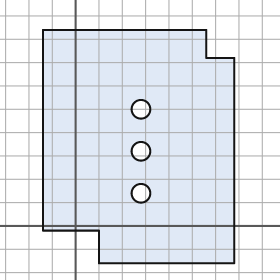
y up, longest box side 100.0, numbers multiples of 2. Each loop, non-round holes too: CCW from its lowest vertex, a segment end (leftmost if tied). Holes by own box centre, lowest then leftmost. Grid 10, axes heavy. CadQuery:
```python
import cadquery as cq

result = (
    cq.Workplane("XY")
    .moveTo(10.0, -16.0)
    .lineTo(68.0, -16.0)
    .lineTo(68.0, 72.0)
    .lineTo(56.0, 72.0)
    .lineTo(56.0, 84.0)
    .lineTo(-14.0, 84.0)
    .lineTo(-14.0, -2.0)
    .lineTo(10.0, -2.0)
    .close()
    .moveTo(28.0, 14.0)
    .circle(4.0)
    .moveTo(28.0, 32.0)
    .circle(4.0)
    .moveTo(28.0, 50.0)
    .circle(4.0)
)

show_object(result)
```